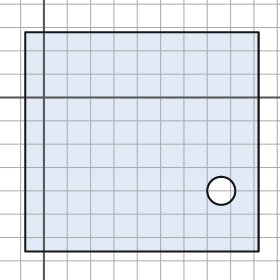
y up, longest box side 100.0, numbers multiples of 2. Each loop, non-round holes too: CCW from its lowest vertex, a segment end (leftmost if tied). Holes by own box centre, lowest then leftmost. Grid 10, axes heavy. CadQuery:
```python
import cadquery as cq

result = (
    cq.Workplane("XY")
    .moveTo(-8.0, -66.0)
    .lineTo(92.0, -66.0)
    .lineTo(92.0, 28.0)
    .lineTo(-8.0, 28.0)
    .close()
    .moveTo(76.0, -40.0)
    .circle(6.0)
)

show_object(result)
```